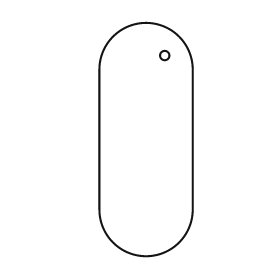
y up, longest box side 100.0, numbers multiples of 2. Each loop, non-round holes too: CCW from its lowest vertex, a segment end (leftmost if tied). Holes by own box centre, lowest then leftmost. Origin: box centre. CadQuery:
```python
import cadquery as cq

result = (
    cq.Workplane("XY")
    .moveTo(-20.0, -30.0)
    .threePointArc((0.0, -50.0), (20.0, -30.0))
    .lineTo(20.0, 30.0)
    .threePointArc((0.0, 50.0), (-20.0, 30.0))
    .close()
    .moveTo(8.0, 36.0)
    .circle(2.0)
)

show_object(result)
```